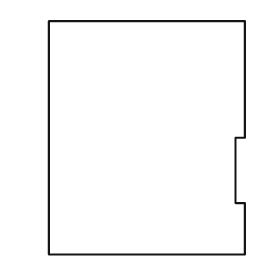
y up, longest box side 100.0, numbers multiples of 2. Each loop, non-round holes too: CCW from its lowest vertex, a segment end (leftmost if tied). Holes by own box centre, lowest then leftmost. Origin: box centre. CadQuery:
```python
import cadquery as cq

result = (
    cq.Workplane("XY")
    .moveTo(-42.0, -50.0)
    .lineTo(42.0, -50.0)
    .lineTo(42.0, -28.0)
    .lineTo(38.0, -28.0)
    .lineTo(38.0, 0.0)
    .lineTo(42.0, 0.0)
    .lineTo(42.0, 50.0)
    .lineTo(-42.0, 50.0)
    .close()
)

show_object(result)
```